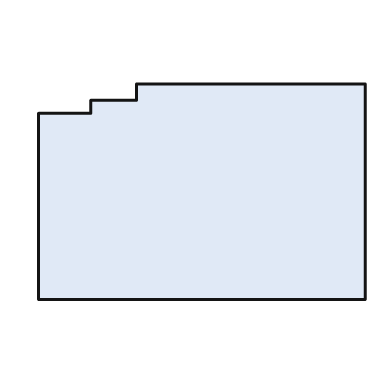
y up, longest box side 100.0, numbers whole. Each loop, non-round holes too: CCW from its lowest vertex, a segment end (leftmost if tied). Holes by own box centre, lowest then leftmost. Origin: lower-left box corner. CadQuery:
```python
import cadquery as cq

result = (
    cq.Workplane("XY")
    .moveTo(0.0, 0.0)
    .lineTo(100.0, 0.0)
    .lineTo(100.0, 66.0)
    .lineTo(30.0, 66.0)
    .lineTo(30.0, 61.0)
    .lineTo(16.0, 61.0)
    .lineTo(16.0, 57.0)
    .lineTo(0.0, 57.0)
    .close()
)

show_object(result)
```